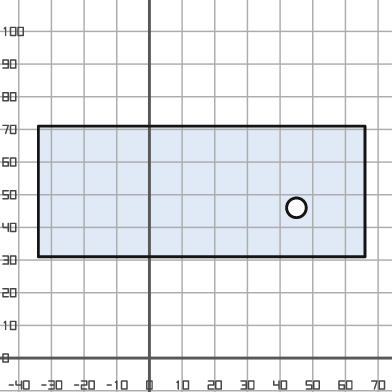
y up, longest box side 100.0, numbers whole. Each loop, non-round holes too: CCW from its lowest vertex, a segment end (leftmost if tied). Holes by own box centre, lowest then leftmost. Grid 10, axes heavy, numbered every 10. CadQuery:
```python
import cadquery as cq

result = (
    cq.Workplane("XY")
    .moveTo(-34.0, 31.0)
    .lineTo(66.0, 31.0)
    .lineTo(66.0, 71.0)
    .lineTo(-34.0, 71.0)
    .close()
    .moveTo(45.0, 46.0)
    .circle(3.0)
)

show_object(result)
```